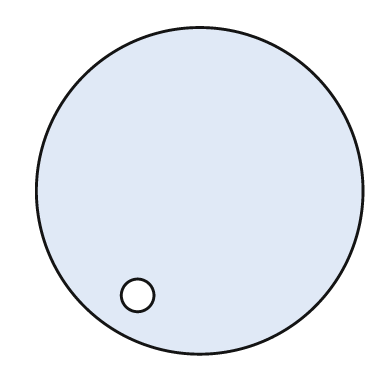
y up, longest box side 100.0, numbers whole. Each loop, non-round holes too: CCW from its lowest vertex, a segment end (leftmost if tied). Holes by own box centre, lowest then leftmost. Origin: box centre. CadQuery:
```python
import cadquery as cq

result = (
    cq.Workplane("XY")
    .moveTo(0.0, 0.0)
    .circle(50.0)
    .moveTo(-19.0, -32.0)
    .circle(5.0)
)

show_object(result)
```